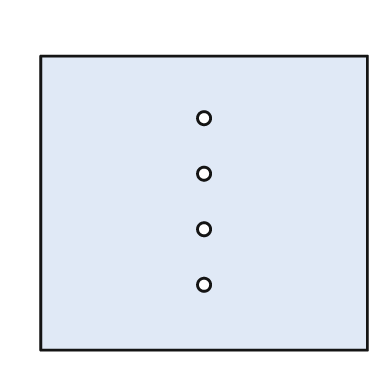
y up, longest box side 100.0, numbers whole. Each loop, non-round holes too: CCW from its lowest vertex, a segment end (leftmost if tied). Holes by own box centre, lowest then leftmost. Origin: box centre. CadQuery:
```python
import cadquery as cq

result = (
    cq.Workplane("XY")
    .moveTo(-50.0, -45.0)
    .lineTo(50.0, -45.0)
    .lineTo(50.0, 45.0)
    .lineTo(-50.0, 45.0)
    .close()
    .moveTo(0.0, -25.0)
    .circle(2.0)
    .moveTo(0.0, -8.0)
    .circle(2.0)
    .moveTo(0.0, 9.0)
    .circle(2.0)
    .moveTo(0.0, 26.0)
    .circle(2.0)
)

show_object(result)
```